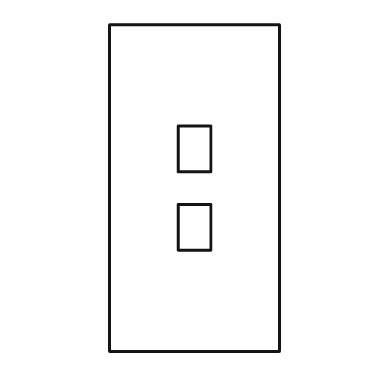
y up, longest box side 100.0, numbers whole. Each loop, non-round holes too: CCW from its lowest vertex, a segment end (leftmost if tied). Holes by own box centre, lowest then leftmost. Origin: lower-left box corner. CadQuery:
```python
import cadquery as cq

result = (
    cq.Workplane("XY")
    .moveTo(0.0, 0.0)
    .lineTo(52.0, 0.0)
    .lineTo(52.0, 100.0)
    .lineTo(0.0, 100.0)
    .close()
    .moveTo(21.0, 31.0)
    .lineTo(31.0, 31.0)
    .lineTo(31.0, 45.0)
    .lineTo(21.0, 45.0)
    .close()
    .moveTo(21.0, 55.0)
    .lineTo(31.0, 55.0)
    .lineTo(31.0, 69.0)
    .lineTo(21.0, 69.0)
    .close()
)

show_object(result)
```